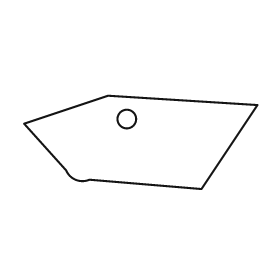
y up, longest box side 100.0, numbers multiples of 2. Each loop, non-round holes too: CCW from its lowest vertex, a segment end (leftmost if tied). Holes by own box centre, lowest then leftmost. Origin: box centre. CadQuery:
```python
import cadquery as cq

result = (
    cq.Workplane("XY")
    .moveTo(26.0, -20.0)
    .lineTo(50.0, 16.0)
    .lineTo(-14.0, 20.0)
    .lineTo(-50.0, 8.0)
    .lineTo(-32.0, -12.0)
    .threePointArc((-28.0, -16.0), (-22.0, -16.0))
    .close()
    .moveTo(-6.0, 10.0)
    .circle(4.0)
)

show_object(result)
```